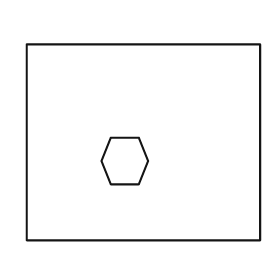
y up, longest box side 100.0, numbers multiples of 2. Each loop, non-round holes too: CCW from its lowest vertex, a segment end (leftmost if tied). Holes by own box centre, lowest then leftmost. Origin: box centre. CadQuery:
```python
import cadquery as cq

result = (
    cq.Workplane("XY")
    .moveTo(-50.0, -42.0)
    .lineTo(50.0, -42.0)
    .lineTo(50.0, 42.0)
    .lineTo(-50.0, 42.0)
    .close()
    .moveTo(-14.0, -18.0)
    .lineTo(-2.0, -18.0)
    .lineTo(2.0, -8.0)
    .lineTo(-2.0, 2.0)
    .lineTo(-14.0, 2.0)
    .lineTo(-18.0, -8.0)
    .close()
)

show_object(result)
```